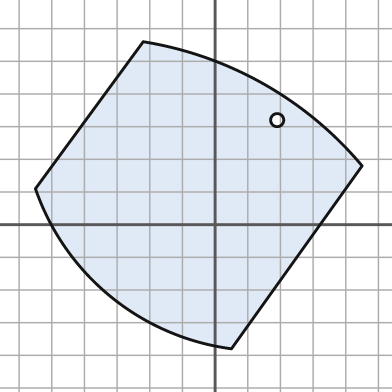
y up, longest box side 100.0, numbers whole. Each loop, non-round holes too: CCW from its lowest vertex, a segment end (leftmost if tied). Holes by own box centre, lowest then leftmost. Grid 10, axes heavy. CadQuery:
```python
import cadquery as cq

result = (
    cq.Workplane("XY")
    .moveTo(5.0, -38.0)
    .lineTo(45.0, 18.0)
    .threePointArc((15.0, 43.0), (-22.0, 56.0))
    .lineTo(-55.0, 11.0)
    .threePointArc((-32.0, -22.0), (5.0, -38.0))
    .close()
    .moveTo(19.0, 32.0)
    .circle(2.0)
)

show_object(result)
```